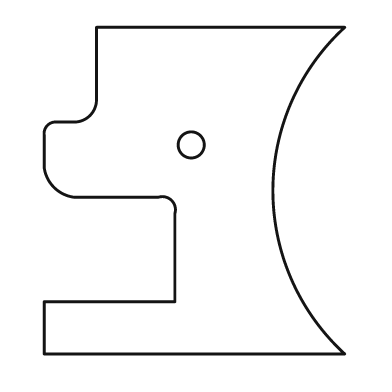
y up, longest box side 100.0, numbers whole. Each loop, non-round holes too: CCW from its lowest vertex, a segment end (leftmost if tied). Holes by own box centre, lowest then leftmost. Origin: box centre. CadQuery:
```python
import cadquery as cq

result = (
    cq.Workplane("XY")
    .moveTo(-46.0, -50.0)
    .lineTo(46.0, -50.0)
    .threePointArc((24.0, 0.0), (46.0, 50.0))
    .lineTo(-30.0, 50.0)
    .lineTo(-30.0, 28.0)
    .threePointArc((-32.0, 23.0), (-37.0, 21.0))
    .lineTo(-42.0, 21.0)
    .threePointArc((-45.0, 20.0), (-46.0, 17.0))
    .lineTo(-46.0, 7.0)
    .threePointArc((-43.0, 1.0), (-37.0, -2.0))
    .lineTo(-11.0, -2.0)
    .threePointArc((-7.0, -3.0), (-6.0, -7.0))
    .lineTo(-6.0, -34.0)
    .lineTo(-46.0, -34.0)
    .close()
    .moveTo(-1.0, 14.0)
    .circle(4.0)
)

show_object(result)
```